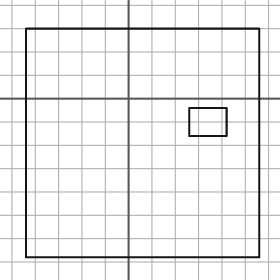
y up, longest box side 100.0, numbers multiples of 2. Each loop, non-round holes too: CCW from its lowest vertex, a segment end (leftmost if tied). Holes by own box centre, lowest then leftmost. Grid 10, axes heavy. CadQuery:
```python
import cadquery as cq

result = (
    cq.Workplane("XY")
    .moveTo(-44.0, -68.0)
    .lineTo(56.0, -68.0)
    .lineTo(56.0, 30.0)
    .lineTo(-44.0, 30.0)
    .close()
    .moveTo(26.0, -16.0)
    .lineTo(42.0, -16.0)
    .lineTo(42.0, -4.0)
    .lineTo(26.0, -4.0)
    .close()
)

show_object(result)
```